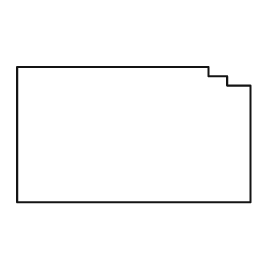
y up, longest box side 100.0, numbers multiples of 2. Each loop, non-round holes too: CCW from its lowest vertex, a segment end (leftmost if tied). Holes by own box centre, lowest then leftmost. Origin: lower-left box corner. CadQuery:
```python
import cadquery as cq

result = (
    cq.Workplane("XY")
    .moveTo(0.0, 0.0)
    .lineTo(100.0, 0.0)
    .lineTo(100.0, 50.0)
    .lineTo(90.0, 50.0)
    .lineTo(90.0, 54.0)
    .lineTo(82.0, 54.0)
    .lineTo(82.0, 58.0)
    .lineTo(0.0, 58.0)
    .close()
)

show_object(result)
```